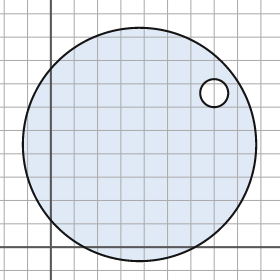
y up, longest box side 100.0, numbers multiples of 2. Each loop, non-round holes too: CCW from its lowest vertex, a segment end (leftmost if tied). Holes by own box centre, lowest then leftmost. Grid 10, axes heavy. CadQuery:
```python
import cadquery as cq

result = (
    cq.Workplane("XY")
    .moveTo(38.0, 44.0)
    .circle(50.0)
    .moveTo(70.0, 66.0)
    .circle(6.0)
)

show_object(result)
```